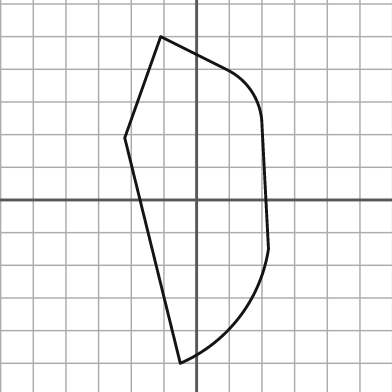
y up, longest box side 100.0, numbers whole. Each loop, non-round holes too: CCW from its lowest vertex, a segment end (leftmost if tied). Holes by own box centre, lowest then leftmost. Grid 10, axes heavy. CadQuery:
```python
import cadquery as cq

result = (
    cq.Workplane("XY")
    .moveTo(-5.0, -50.0)
    .threePointArc((13.0, -36.0), (22.0, -15.0))
    .lineTo(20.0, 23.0)
    .threePointArc((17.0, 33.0), (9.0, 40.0))
    .lineTo(-11.0, 50.0)
    .lineTo(-22.0, 19.0)
    .close()
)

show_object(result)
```